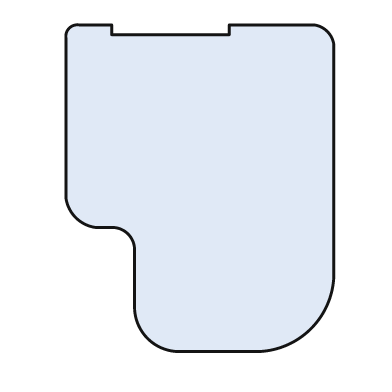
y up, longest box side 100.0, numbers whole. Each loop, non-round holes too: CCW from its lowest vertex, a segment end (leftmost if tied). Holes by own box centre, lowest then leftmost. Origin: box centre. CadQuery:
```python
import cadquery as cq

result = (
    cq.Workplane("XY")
    .moveTo(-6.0, -50.0)
    .lineTo(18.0, -50.0)
    .threePointArc((34.0, -43.0), (41.0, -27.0))
    .lineTo(41.0, 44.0)
    .threePointArc((39.0, 48.0), (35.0, 50.0))
    .lineTo(9.0, 50.0)
    .lineTo(9.0, 47.0)
    .lineTo(-27.0, 47.0)
    .lineTo(-27.0, 50.0)
    .lineTo(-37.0, 50.0)
    .threePointArc((-40.0, 49.0), (-41.0, 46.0))
    .lineTo(-41.0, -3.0)
    .threePointArc((-38.0, -9.0), (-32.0, -12.0))
    .lineTo(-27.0, -12.0)
    .threePointArc((-22.0, -14.0), (-20.0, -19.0))
    .lineTo(-20.0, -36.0)
    .threePointArc((-16.0, -46.0), (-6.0, -50.0))
    .close()
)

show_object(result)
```